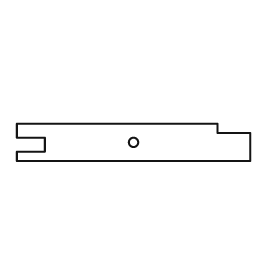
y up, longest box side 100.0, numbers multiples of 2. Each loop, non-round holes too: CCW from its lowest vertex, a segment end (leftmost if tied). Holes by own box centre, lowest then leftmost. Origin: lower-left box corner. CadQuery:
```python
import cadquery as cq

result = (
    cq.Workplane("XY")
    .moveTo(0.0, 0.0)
    .lineTo(100.0, 0.0)
    .lineTo(100.0, 12.0)
    .lineTo(86.0, 12.0)
    .lineTo(86.0, 16.0)
    .lineTo(0.0, 16.0)
    .lineTo(0.0, 10.0)
    .lineTo(12.0, 10.0)
    .lineTo(12.0, 4.0)
    .lineTo(0.0, 4.0)
    .close()
    .moveTo(50.0, 8.0)
    .circle(2.0)
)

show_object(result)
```